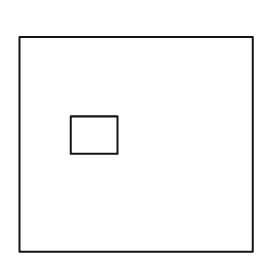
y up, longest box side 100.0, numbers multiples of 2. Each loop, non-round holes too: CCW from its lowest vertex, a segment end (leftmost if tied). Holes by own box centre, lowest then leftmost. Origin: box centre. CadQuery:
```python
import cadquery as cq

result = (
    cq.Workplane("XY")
    .moveTo(-50.0, -46.0)
    .lineTo(50.0, -46.0)
    .lineTo(50.0, 46.0)
    .lineTo(-50.0, 46.0)
    .close()
    .moveTo(-28.0, -4.0)
    .lineTo(-8.0, -4.0)
    .lineTo(-8.0, 12.0)
    .lineTo(-28.0, 12.0)
    .close()
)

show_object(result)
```